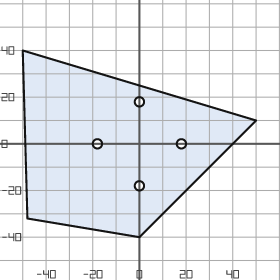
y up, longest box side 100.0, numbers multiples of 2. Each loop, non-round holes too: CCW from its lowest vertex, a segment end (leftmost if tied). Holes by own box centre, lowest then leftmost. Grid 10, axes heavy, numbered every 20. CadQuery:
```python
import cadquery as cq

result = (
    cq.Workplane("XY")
    .moveTo(0.0, -40.0)
    .lineTo(50.0, 10.0)
    .lineTo(-50.0, 40.0)
    .lineTo(-48.0, -32.0)
    .close()
    .moveTo(0.0, -18.0)
    .circle(2.0)
    .moveTo(-18.0, 0.0)
    .circle(2.0)
    .moveTo(18.0, 0.0)
    .circle(2.0)
    .moveTo(0.0, 18.0)
    .circle(2.0)
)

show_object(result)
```